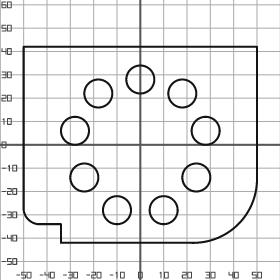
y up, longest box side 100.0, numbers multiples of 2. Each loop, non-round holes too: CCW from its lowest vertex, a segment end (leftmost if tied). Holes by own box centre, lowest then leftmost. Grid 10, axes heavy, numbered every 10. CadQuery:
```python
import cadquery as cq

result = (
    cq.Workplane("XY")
    .moveTo(-34.0, -42.0)
    .lineTo(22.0, -42.0)
    .threePointArc((42.0, -34.0), (50.0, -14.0))
    .lineTo(50.0, 42.0)
    .lineTo(-50.0, 42.0)
    .lineTo(-50.0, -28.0)
    .threePointArc((-48.0, -32.0), (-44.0, -34.0))
    .lineTo(-34.0, -34.0)
    .close()
    .moveTo(-10.0, -28.0)
    .circle(6.0)
    .moveTo(10.0, -28.0)
    .circle(6.0)
    .moveTo(-24.0, -14.0)
    .circle(6.0)
    .moveTo(24.0, -14.0)
    .circle(6.0)
    .moveTo(-28.0, 6.0)
    .circle(6.0)
    .moveTo(28.0, 6.0)
    .circle(6.0)
    .moveTo(-18.0, 22.0)
    .circle(6.0)
    .moveTo(18.0, 22.0)
    .circle(6.0)
    .moveTo(0.0, 28.0)
    .circle(6.0)
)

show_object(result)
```